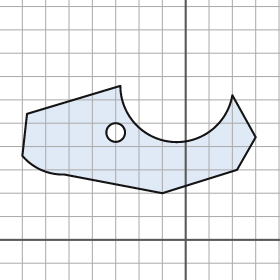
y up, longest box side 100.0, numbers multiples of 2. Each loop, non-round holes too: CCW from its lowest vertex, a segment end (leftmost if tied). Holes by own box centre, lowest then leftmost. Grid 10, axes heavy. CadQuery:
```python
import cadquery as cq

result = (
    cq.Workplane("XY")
    .moveTo(-10.0, 20.0)
    .lineTo(22.0, 30.0)
    .lineTo(30.0, 44.0)
    .lineTo(20.0, 62.0)
    .threePointArc((-6.0, 42.0), (-28.0, 66.0))
    .lineTo(-68.0, 54.0)
    .lineTo(-70.0, 36.0)
    .threePointArc((-62.0, 30.0), (-52.0, 28.0))
    .close()
    .moveTo(-30.0, 46.0)
    .circle(4.0)
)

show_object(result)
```